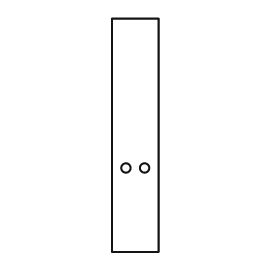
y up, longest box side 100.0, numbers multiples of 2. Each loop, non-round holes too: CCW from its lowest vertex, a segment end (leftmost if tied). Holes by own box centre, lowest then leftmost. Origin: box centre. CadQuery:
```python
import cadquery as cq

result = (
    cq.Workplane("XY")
    .moveTo(-10.0, -50.0)
    .lineTo(10.0, -50.0)
    .lineTo(10.0, 50.0)
    .lineTo(-10.0, 50.0)
    .close()
    .moveTo(-4.0, -14.0)
    .circle(2.0)
    .moveTo(4.0, -14.0)
    .circle(2.0)
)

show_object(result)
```